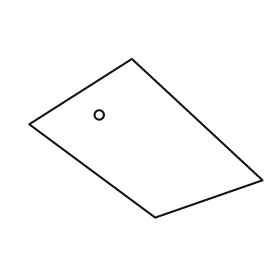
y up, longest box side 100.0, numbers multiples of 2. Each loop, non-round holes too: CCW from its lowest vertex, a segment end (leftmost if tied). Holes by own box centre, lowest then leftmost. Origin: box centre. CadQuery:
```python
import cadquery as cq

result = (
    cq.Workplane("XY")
    .moveTo(4.0, -34.0)
    .lineTo(50.0, -18.0)
    .lineTo(-6.0, 34.0)
    .lineTo(-50.0, 6.0)
    .close()
    .moveTo(-20.0, 10.0)
    .circle(2.0)
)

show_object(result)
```